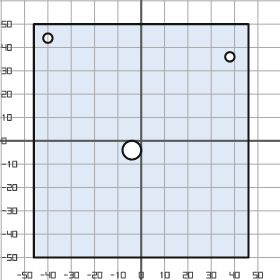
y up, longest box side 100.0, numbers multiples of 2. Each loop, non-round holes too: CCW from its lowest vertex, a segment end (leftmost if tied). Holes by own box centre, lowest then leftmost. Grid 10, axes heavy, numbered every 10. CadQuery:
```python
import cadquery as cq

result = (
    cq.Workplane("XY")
    .moveTo(-46.0, -50.0)
    .lineTo(46.0, -50.0)
    .lineTo(46.0, 50.0)
    .lineTo(-46.0, 50.0)
    .close()
    .moveTo(-4.0, -4.0)
    .circle(4.0)
    .moveTo(38.0, 36.0)
    .circle(2.0)
    .moveTo(-40.0, 44.0)
    .circle(2.0)
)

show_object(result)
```